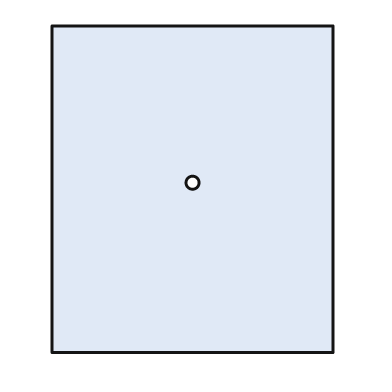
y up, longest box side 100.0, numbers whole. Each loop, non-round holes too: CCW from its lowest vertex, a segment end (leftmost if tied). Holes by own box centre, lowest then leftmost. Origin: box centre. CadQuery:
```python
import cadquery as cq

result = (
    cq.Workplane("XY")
    .moveTo(-43.0, -50.0)
    .lineTo(43.0, -50.0)
    .lineTo(43.0, 50.0)
    .lineTo(-43.0, 50.0)
    .close()
    .moveTo(0.0, 2.0)
    .circle(2.0)
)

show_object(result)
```